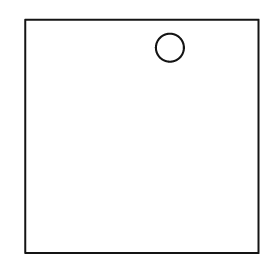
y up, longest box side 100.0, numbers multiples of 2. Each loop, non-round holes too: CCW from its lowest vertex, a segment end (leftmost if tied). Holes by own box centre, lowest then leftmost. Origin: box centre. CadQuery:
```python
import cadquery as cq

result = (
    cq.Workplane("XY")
    .moveTo(-50.0, -50.0)
    .lineTo(50.0, -50.0)
    .lineTo(50.0, 50.0)
    .lineTo(-50.0, 50.0)
    .close()
    .moveTo(12.0, 38.0)
    .circle(6.0)
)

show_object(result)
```